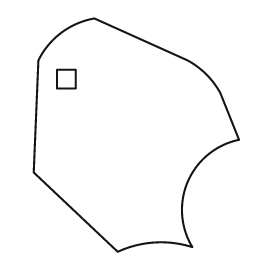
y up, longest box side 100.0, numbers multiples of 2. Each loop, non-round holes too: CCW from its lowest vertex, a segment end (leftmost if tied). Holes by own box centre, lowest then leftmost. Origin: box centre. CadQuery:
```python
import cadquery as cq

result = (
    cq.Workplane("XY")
    .moveTo(-8.0, -50.0)
    .threePointArc((8.0, -46.0), (24.0, -48.0))
    .threePointArc((22.0, -20.0), (44.0, -2.0))
    .lineTo(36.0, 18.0)
    .threePointArc((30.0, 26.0), (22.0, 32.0))
    .lineTo(-18.0, 50.0)
    .threePointArc((-32.0, 44.0), (-42.0, 32.0))
    .lineTo(-44.0, -16.0)
    .close()
    .moveTo(-34.0, 20.0)
    .lineTo(-26.0, 20.0)
    .lineTo(-26.0, 28.0)
    .lineTo(-34.0, 28.0)
    .close()
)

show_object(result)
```